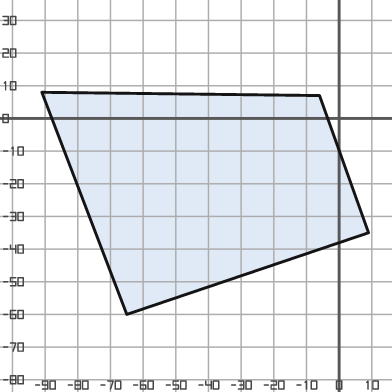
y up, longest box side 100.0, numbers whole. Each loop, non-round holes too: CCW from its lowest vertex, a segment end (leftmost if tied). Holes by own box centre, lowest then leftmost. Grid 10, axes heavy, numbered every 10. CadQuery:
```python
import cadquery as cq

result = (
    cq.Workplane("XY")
    .moveTo(-65.0, -60.0)
    .lineTo(9.0, -35.0)
    .lineTo(-6.0, 7.0)
    .lineTo(-91.0, 8.0)
    .close()
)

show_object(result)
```